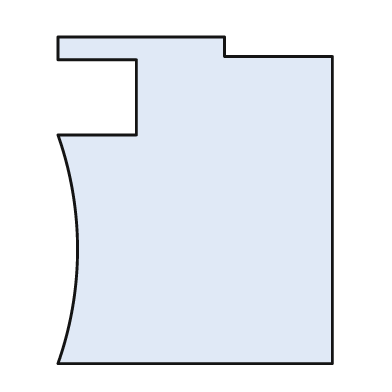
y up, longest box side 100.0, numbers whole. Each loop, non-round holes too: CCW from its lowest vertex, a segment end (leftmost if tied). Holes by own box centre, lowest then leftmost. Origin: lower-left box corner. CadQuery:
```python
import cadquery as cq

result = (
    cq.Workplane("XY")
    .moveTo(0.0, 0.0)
    .lineTo(84.0, 0.0)
    .lineTo(84.0, 94.0)
    .lineTo(51.0, 94.0)
    .lineTo(51.0, 100.0)
    .lineTo(0.0, 100.0)
    .lineTo(0.0, 93.0)
    .lineTo(24.0, 93.0)
    .lineTo(24.0, 70.0)
    .lineTo(0.0, 70.0)
    .threePointArc((6.0, 35.0), (0.0, 0.0))
    .close()
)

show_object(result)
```